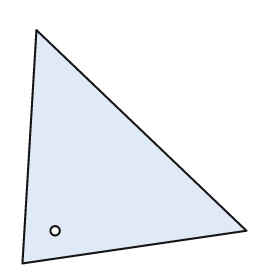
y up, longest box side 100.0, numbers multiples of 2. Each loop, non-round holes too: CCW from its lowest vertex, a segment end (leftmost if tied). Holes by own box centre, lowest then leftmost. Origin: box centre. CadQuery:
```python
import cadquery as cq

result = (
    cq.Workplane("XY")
    .moveTo(-48.0, -50.0)
    .lineTo(48.0, -36.0)
    .lineTo(-42.0, 50.0)
    .close()
    .moveTo(-34.0, -36.0)
    .circle(2.0)
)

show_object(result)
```